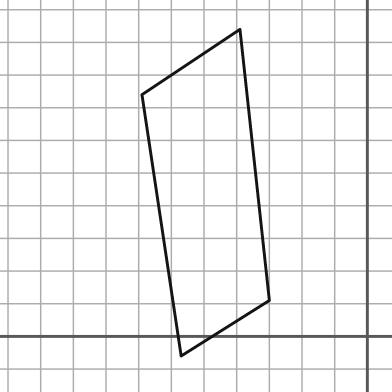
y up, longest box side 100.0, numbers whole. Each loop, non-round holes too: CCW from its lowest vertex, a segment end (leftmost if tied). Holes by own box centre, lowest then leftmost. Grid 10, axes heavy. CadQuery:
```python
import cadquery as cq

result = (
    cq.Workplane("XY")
    .moveTo(-57.0, -6.0)
    .lineTo(-30.0, 11.0)
    .lineTo(-39.0, 94.0)
    .lineTo(-69.0, 74.0)
    .close()
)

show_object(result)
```